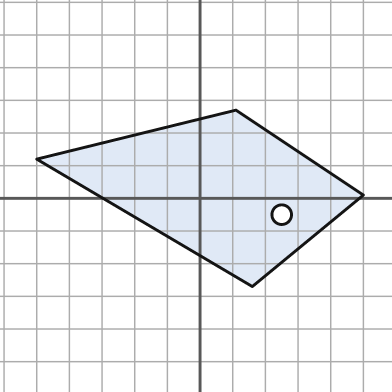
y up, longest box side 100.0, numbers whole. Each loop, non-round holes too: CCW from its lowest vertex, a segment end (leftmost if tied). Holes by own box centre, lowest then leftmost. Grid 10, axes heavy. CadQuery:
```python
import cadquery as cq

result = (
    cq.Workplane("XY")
    .moveTo(16.0, -27.0)
    .lineTo(50.0, 1.0)
    .lineTo(11.0, 27.0)
    .lineTo(-50.0, 12.0)
    .close()
    .moveTo(25.0, -5.0)
    .circle(3.0)
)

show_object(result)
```